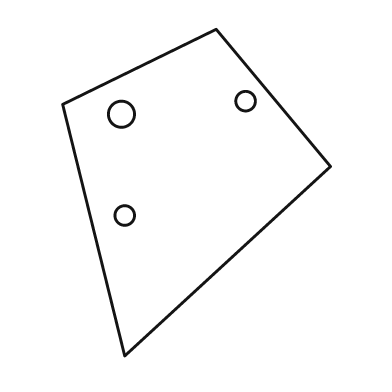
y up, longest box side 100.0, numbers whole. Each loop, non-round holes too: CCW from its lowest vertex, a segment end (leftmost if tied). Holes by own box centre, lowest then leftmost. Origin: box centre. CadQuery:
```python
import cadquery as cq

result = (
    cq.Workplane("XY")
    .moveTo(-22.0, -50.0)
    .lineTo(41.0, 8.0)
    .lineTo(6.0, 50.0)
    .lineTo(-41.0, 27.0)
    .close()
    .moveTo(-22.0, -7.0)
    .circle(3.0)
    .moveTo(-23.0, 24.0)
    .circle(4.0)
    .moveTo(15.0, 28.0)
    .circle(3.0)
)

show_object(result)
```